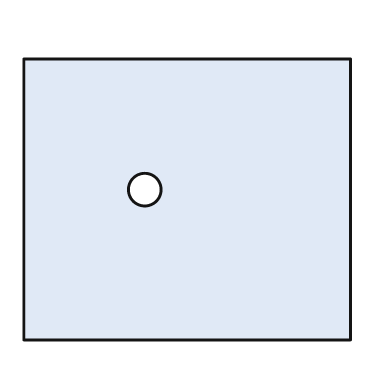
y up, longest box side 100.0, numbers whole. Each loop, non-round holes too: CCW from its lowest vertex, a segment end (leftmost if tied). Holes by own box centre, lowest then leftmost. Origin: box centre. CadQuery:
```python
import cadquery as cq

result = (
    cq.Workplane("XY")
    .moveTo(-50.0, -43.0)
    .lineTo(50.0, -43.0)
    .lineTo(50.0, 43.0)
    .lineTo(-50.0, 43.0)
    .close()
    .moveTo(-13.0, 3.0)
    .circle(5.0)
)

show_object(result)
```